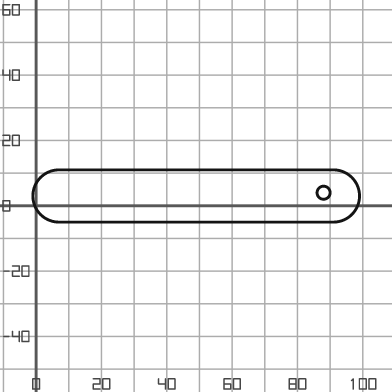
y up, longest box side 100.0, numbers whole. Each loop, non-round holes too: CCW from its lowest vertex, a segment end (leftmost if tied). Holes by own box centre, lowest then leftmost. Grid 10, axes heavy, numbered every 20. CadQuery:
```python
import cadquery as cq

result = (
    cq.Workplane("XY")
    .moveTo(7.0, -5.0)
    .lineTo(91.0, -5.0)
    .threePointArc((99.0, 3.0), (91.0, 11.0))
    .lineTo(7.0, 11.0)
    .threePointArc((-1.0, 3.0), (7.0, -5.0))
    .close()
    .moveTo(88.0, 4.0)
    .circle(2.0)
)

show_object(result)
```